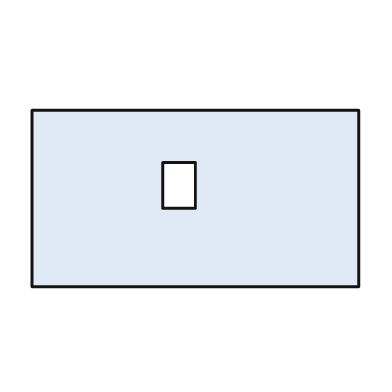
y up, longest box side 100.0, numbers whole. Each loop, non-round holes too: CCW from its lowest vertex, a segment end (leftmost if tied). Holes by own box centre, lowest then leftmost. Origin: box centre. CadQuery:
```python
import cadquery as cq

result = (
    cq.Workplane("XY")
    .moveTo(-50.0, -27.0)
    .lineTo(50.0, -27.0)
    .lineTo(50.0, 27.0)
    .lineTo(-50.0, 27.0)
    .close()
    .moveTo(-10.0, -3.0)
    .lineTo(0.0, -3.0)
    .lineTo(0.0, 11.0)
    .lineTo(-10.0, 11.0)
    .close()
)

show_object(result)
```